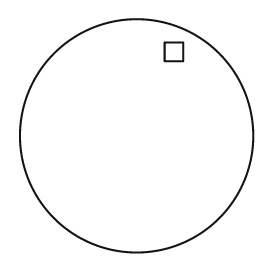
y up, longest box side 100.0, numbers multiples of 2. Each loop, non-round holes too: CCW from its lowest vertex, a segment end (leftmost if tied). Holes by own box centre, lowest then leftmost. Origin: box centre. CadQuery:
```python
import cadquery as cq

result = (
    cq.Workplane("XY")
    .moveTo(0.0, 0.0)
    .circle(50.0)
    .moveTo(12.0, 32.0)
    .lineTo(20.0, 32.0)
    .lineTo(20.0, 40.0)
    .lineTo(12.0, 40.0)
    .close()
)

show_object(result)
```